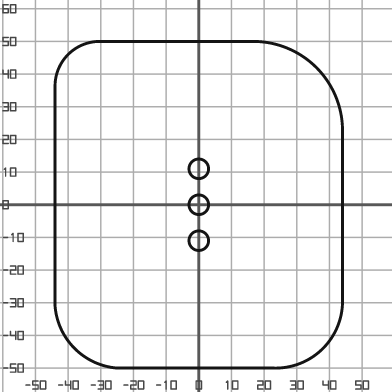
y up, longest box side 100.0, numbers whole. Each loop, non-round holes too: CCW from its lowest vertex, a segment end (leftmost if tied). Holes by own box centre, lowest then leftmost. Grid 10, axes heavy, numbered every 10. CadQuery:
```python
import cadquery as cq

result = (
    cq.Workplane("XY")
    .moveTo(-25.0, -50.0)
    .lineTo(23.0, -50.0)
    .threePointArc((38.0, -44.0), (44.0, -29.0))
    .lineTo(44.0, 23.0)
    .threePointArc((36.0, 42.0), (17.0, 50.0))
    .lineTo(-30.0, 50.0)
    .threePointArc((-40.0, 46.0), (-44.0, 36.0))
    .lineTo(-44.0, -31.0)
    .threePointArc((-38.0, -44.0), (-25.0, -50.0))
    .close()
    .moveTo(0.0, -11.0)
    .circle(3.0)
    .moveTo(0.0, 0.0)
    .circle(3.0)
    .moveTo(0.0, 11.0)
    .circle(3.0)
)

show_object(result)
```